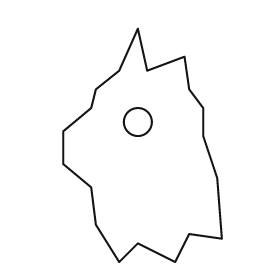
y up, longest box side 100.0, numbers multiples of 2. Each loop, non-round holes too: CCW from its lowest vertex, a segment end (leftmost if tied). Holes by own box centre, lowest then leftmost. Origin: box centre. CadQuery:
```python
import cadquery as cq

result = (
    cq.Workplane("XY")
    .moveTo(-10.0, -50.0)
    .lineTo(-2.0, -42.0)
    .lineTo(14.0, -50.0)
    .lineTo(20.0, -38.0)
    .lineTo(34.0, -40.0)
    .lineTo(32.0, -14.0)
    .lineTo(26.0, 4.0)
    .lineTo(26.0, 16.0)
    .lineTo(20.0, 24.0)
    .lineTo(18.0, 38.0)
    .lineTo(2.0, 32.0)
    .lineTo(-2.0, 50.0)
    .lineTo(-10.0, 32.0)
    .lineTo(-20.0, 24.0)
    .lineTo(-22.0, 16.0)
    .lineTo(-34.0, 6.0)
    .lineTo(-34.0, -8.0)
    .lineTo(-22.0, -18.0)
    .lineTo(-20.0, -34.0)
    .close()
    .moveTo(-2.0, 10.0)
    .circle(6.0)
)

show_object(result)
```